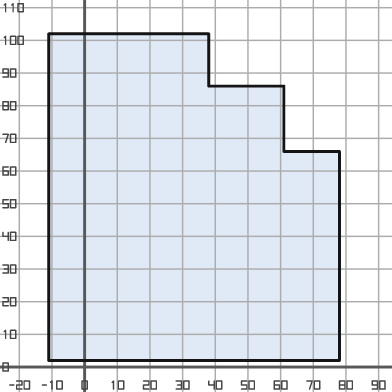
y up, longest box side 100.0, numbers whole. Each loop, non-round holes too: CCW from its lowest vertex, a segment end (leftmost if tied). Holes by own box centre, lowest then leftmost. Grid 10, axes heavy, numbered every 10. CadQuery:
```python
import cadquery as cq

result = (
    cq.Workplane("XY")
    .moveTo(-11.0, 2.0)
    .lineTo(78.0, 2.0)
    .lineTo(78.0, 66.0)
    .lineTo(61.0, 66.0)
    .lineTo(61.0, 86.0)
    .lineTo(38.0, 86.0)
    .lineTo(38.0, 102.0)
    .lineTo(-11.0, 102.0)
    .close()
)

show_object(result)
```